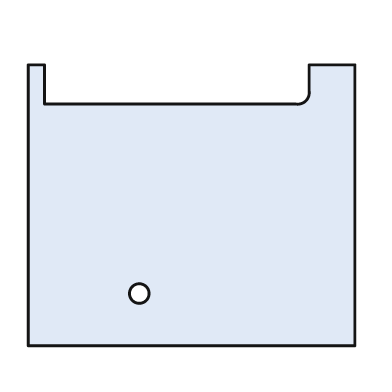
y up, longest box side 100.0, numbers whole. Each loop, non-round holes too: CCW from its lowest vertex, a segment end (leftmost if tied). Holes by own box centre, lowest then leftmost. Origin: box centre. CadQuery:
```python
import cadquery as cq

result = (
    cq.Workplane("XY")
    .moveTo(-50.0, -43.0)
    .lineTo(50.0, -43.0)
    .lineTo(50.0, 43.0)
    .lineTo(36.0, 43.0)
    .lineTo(36.0, 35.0)
    .threePointArc((35.0, 32.0), (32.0, 31.0))
    .lineTo(-45.0, 31.0)
    .lineTo(-45.0, 43.0)
    .lineTo(-50.0, 43.0)
    .close()
    .moveTo(-16.0, -27.0)
    .circle(3.0)
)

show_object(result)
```